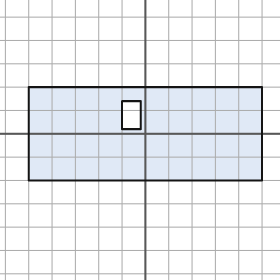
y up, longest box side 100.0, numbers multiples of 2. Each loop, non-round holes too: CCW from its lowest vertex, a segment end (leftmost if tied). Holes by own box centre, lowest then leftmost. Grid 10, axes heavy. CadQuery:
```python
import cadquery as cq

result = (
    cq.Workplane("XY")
    .moveTo(-50.0, -20.0)
    .lineTo(50.0, -20.0)
    .lineTo(50.0, 20.0)
    .lineTo(-50.0, 20.0)
    .close()
    .moveTo(-10.0, 2.0)
    .lineTo(-2.0, 2.0)
    .lineTo(-2.0, 14.0)
    .lineTo(-10.0, 14.0)
    .close()
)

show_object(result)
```